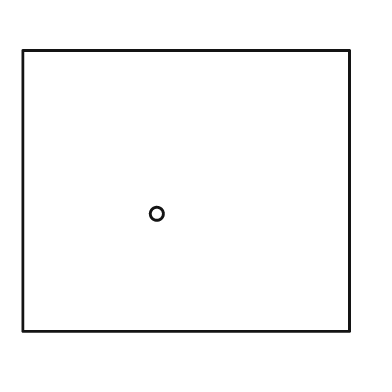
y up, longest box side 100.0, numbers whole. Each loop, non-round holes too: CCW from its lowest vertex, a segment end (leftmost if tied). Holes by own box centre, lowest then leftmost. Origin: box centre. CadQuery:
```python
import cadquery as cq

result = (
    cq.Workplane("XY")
    .moveTo(-50.0, -43.0)
    .lineTo(50.0, -43.0)
    .lineTo(50.0, 43.0)
    .lineTo(-50.0, 43.0)
    .close()
    .moveTo(-9.0, -7.0)
    .circle(2.0)
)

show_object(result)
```